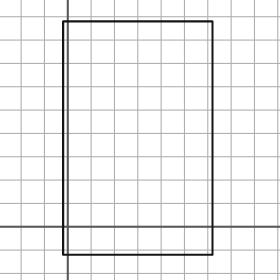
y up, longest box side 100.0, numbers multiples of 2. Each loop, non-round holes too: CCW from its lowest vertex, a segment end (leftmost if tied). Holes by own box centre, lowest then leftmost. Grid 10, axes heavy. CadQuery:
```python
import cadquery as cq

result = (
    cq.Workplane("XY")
    .moveTo(-2.0, -12.0)
    .lineTo(62.0, -12.0)
    .lineTo(62.0, 88.0)
    .lineTo(-2.0, 88.0)
    .close()
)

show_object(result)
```